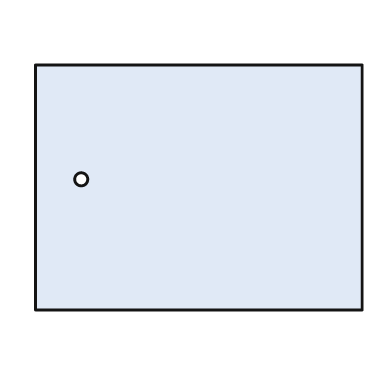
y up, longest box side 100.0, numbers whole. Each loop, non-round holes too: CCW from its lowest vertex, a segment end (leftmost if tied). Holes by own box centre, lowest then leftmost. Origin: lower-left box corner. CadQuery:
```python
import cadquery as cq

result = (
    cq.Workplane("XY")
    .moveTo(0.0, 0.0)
    .lineTo(100.0, 0.0)
    .lineTo(100.0, 75.0)
    .lineTo(0.0, 75.0)
    .close()
    .moveTo(14.0, 40.0)
    .circle(2.0)
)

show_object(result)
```